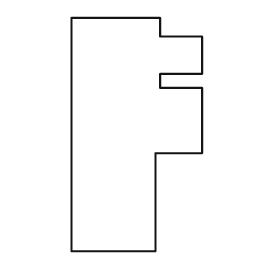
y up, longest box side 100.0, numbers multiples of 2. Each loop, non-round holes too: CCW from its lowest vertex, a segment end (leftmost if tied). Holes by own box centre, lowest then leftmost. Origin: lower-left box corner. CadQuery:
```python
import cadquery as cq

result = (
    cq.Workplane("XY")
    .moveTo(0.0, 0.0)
    .lineTo(36.0, 0.0)
    .lineTo(36.0, 42.0)
    .lineTo(56.0, 42.0)
    .lineTo(56.0, 70.0)
    .lineTo(38.0, 70.0)
    .lineTo(38.0, 76.0)
    .lineTo(56.0, 76.0)
    .lineTo(56.0, 92.0)
    .lineTo(38.0, 92.0)
    .lineTo(38.0, 100.0)
    .lineTo(0.0, 100.0)
    .close()
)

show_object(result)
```